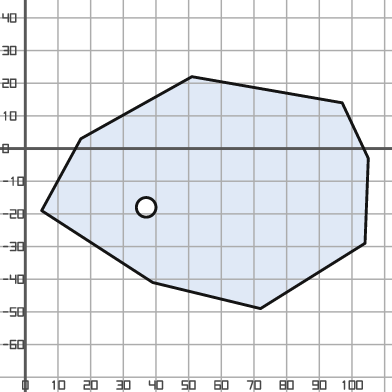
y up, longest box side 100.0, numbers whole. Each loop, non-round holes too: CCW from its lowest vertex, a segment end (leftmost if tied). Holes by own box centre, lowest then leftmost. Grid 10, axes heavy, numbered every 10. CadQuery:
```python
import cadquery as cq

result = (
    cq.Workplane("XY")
    .moveTo(72.0, -49.0)
    .lineTo(104.0, -29.0)
    .lineTo(105.0, -3.0)
    .lineTo(97.0, 14.0)
    .lineTo(51.0, 22.0)
    .lineTo(17.0, 3.0)
    .lineTo(5.0, -19.0)
    .lineTo(39.0, -41.0)
    .close()
    .moveTo(37.0, -18.0)
    .circle(3.0)
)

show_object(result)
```